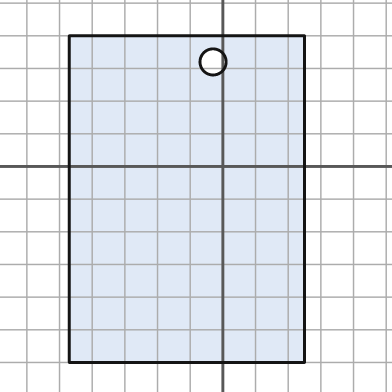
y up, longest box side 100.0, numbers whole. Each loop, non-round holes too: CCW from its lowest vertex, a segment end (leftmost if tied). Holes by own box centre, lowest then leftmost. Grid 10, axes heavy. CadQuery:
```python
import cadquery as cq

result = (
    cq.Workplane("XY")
    .moveTo(-47.0, -60.0)
    .lineTo(25.0, -60.0)
    .lineTo(25.0, 40.0)
    .lineTo(-47.0, 40.0)
    .close()
    .moveTo(-3.0, 32.0)
    .circle(4.0)
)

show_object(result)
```